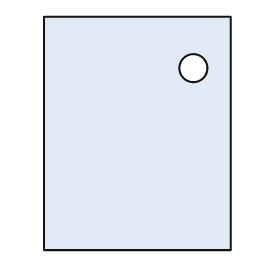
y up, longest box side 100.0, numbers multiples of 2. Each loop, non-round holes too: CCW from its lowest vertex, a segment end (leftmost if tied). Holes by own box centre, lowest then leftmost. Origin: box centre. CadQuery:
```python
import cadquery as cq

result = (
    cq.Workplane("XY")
    .moveTo(-40.0, -50.0)
    .lineTo(40.0, -50.0)
    .lineTo(40.0, 50.0)
    .lineTo(-40.0, 50.0)
    .close()
    .moveTo(24.0, 28.0)
    .circle(6.0)
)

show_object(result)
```